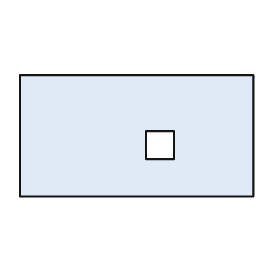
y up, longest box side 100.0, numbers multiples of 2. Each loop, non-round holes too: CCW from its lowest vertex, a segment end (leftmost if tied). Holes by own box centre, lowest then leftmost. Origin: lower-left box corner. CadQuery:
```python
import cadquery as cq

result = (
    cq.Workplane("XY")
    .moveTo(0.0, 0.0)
    .lineTo(100.0, 0.0)
    .lineTo(100.0, 52.0)
    .lineTo(0.0, 52.0)
    .close()
    .moveTo(54.0, 16.0)
    .lineTo(66.0, 16.0)
    .lineTo(66.0, 28.0)
    .lineTo(54.0, 28.0)
    .close()
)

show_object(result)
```